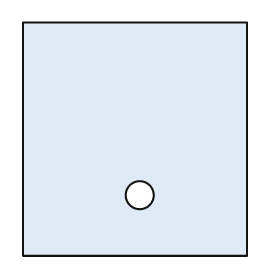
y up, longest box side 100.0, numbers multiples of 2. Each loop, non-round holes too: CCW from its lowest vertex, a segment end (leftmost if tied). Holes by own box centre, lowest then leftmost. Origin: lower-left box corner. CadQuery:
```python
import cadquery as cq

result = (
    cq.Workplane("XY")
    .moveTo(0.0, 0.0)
    .lineTo(96.0, 0.0)
    .lineTo(96.0, 100.0)
    .lineTo(0.0, 100.0)
    .close()
    .moveTo(50.0, 26.0)
    .circle(6.0)
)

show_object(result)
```